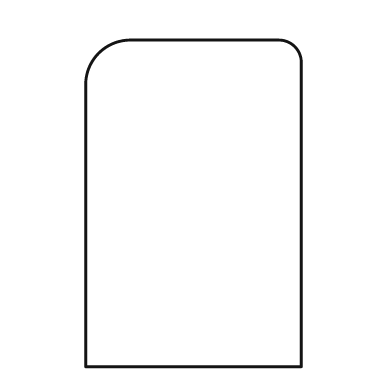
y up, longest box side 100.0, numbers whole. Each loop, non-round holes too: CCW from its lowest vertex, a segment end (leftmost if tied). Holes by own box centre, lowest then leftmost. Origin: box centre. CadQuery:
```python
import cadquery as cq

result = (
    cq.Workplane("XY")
    .moveTo(-33.0, -50.0)
    .lineTo(33.0, -50.0)
    .lineTo(33.0, 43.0)
    .threePointArc((31.0, 48.0), (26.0, 50.0))
    .lineTo(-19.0, 50.0)
    .threePointArc((-29.0, 46.0), (-33.0, 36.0))
    .close()
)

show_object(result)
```